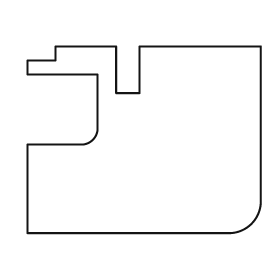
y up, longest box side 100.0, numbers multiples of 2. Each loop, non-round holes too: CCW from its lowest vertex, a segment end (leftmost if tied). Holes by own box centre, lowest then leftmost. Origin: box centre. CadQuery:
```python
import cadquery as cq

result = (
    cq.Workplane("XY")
    .moveTo(-50.0, -40.0)
    .lineTo(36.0, -40.0)
    .threePointArc((46.0, -36.0), (50.0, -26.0))
    .lineTo(50.0, 40.0)
    .lineTo(-2.0, 40.0)
    .lineTo(-2.0, 20.0)
    .lineTo(-12.0, 20.0)
    .lineTo(-12.0, 40.0)
    .lineTo(-38.0, 40.0)
    .lineTo(-38.0, 34.0)
    .lineTo(-50.0, 34.0)
    .lineTo(-50.0, 28.0)
    .lineTo(-20.0, 28.0)
    .lineTo(-20.0, 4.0)
    .threePointArc((-22.0, 0.0), (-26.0, -2.0))
    .lineTo(-50.0, -2.0)
    .close()
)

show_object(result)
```